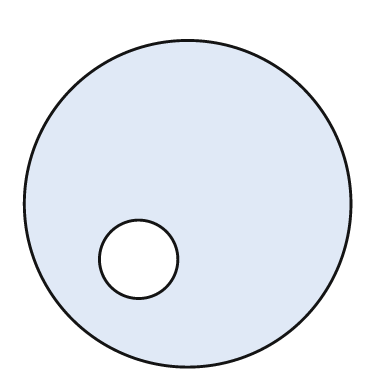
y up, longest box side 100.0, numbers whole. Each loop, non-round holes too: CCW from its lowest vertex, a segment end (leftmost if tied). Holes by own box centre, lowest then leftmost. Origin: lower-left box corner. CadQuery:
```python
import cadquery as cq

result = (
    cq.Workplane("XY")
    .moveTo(50.0, 50.0)
    .circle(50.0)
    .moveTo(35.0, 33.0)
    .circle(12.0)
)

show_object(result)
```